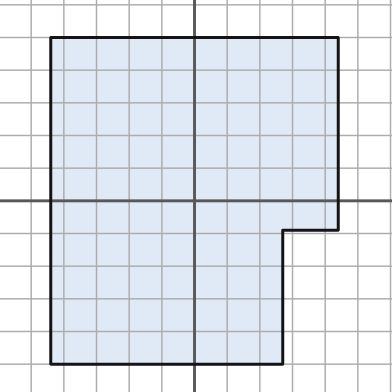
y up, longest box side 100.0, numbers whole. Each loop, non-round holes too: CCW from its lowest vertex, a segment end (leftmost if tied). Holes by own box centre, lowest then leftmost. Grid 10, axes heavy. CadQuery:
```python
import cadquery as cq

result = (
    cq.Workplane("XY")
    .moveTo(-44.0, -50.0)
    .lineTo(27.0, -50.0)
    .lineTo(27.0, -9.0)
    .lineTo(44.0, -9.0)
    .lineTo(44.0, 50.0)
    .lineTo(-44.0, 50.0)
    .close()
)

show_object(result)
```